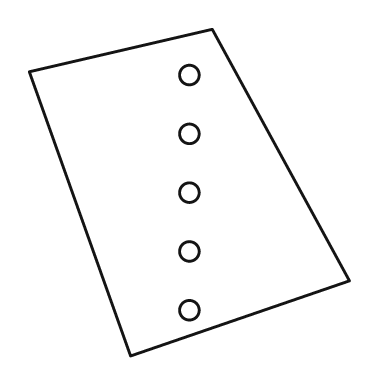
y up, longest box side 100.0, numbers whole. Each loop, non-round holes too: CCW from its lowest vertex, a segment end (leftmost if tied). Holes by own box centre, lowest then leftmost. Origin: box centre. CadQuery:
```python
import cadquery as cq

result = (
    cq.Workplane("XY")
    .moveTo(-18.0, -50.0)
    .lineTo(49.0, -27.0)
    .lineTo(7.0, 50.0)
    .lineTo(-49.0, 37.0)
    .close()
    .moveTo(0.0, -36.0)
    .circle(3.0)
    .moveTo(0.0, -18.0)
    .circle(3.0)
    .moveTo(0.0, 0.0)
    .circle(3.0)
    .moveTo(0.0, 18.0)
    .circle(3.0)
    .moveTo(0.0, 36.0)
    .circle(3.0)
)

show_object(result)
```